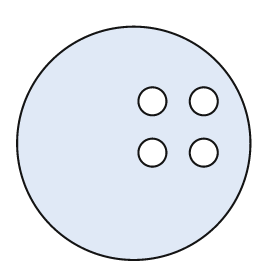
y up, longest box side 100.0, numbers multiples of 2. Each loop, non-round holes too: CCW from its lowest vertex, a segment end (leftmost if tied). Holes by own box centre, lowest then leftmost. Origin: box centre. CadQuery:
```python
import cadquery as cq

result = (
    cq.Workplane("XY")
    .moveTo(0.0, 0.0)
    .circle(50.0)
    .moveTo(8.0, -4.0)
    .circle(6.0)
    .moveTo(30.0, -4.0)
    .circle(6.0)
    .moveTo(8.0, 18.0)
    .circle(6.0)
    .moveTo(30.0, 18.0)
    .circle(6.0)
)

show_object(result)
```